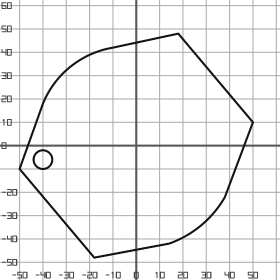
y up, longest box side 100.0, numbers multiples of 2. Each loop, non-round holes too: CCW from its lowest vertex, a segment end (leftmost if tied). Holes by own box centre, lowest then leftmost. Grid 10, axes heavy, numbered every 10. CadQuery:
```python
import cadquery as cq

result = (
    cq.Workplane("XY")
    .moveTo(-18.0, -48.0)
    .lineTo(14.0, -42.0)
    .threePointArc((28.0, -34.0), (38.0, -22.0))
    .lineTo(50.0, 10.0)
    .lineTo(18.0, 48.0)
    .lineTo(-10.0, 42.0)
    .threePointArc((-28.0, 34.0), (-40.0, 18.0))
    .lineTo(-50.0, -10.0)
    .close()
    .moveTo(-40.0, -6.0)
    .circle(4.0)
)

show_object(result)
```